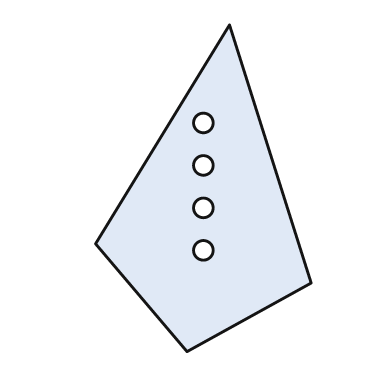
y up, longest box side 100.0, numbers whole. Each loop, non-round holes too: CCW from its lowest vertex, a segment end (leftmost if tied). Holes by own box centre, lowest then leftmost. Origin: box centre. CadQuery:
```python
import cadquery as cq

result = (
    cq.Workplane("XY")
    .moveTo(-5.0, -50.0)
    .lineTo(33.0, -29.0)
    .lineTo(8.0, 50.0)
    .lineTo(-33.0, -17.0)
    .close()
    .moveTo(0.0, -19.0)
    .circle(3.0)
    .moveTo(0.0, -6.0)
    .circle(3.0)
    .moveTo(0.0, 7.0)
    .circle(3.0)
    .moveTo(0.0, 20.0)
    .circle(3.0)
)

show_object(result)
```